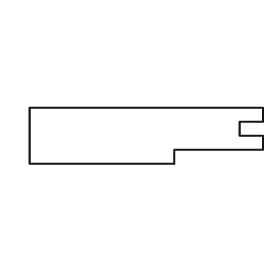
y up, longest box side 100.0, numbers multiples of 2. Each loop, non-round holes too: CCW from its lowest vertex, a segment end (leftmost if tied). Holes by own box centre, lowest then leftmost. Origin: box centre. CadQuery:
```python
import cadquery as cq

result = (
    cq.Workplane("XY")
    .moveTo(-50.0, -12.0)
    .lineTo(12.0, -12.0)
    .lineTo(12.0, -6.0)
    .lineTo(50.0, -6.0)
    .lineTo(50.0, 0.0)
    .lineTo(40.0, 0.0)
    .lineTo(40.0, 6.0)
    .lineTo(50.0, 6.0)
    .lineTo(50.0, 12.0)
    .lineTo(-50.0, 12.0)
    .close()
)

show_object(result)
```